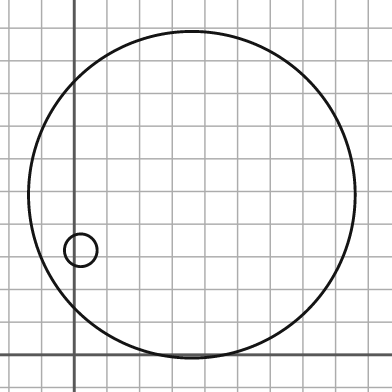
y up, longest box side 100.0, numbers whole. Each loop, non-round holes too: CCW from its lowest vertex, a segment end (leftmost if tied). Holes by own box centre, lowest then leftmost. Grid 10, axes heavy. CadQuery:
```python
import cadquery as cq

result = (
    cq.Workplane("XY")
    .moveTo(36.0, 49.0)
    .circle(50.0)
    .moveTo(2.0, 32.0)
    .circle(5.0)
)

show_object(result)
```